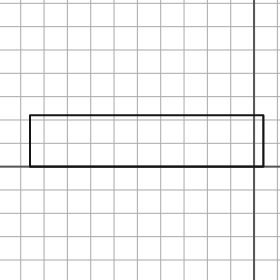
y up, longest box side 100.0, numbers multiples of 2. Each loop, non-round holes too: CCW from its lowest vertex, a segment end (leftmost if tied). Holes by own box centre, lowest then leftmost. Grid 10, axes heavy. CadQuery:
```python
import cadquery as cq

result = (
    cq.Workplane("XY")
    .moveTo(-96.0, 0.0)
    .lineTo(4.0, 0.0)
    .lineTo(4.0, 22.0)
    .lineTo(-96.0, 22.0)
    .close()
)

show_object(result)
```